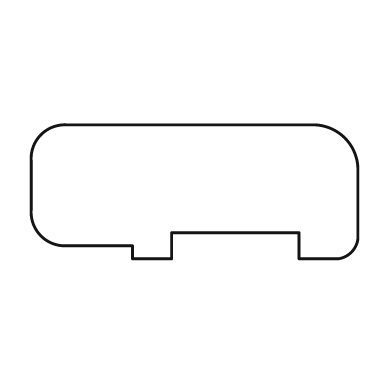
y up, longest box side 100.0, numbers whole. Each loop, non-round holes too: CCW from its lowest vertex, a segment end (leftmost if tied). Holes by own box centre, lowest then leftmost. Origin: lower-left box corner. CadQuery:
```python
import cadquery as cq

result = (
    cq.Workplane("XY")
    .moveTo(31.0, 0.0)
    .lineTo(43.0, 0.0)
    .lineTo(43.0, 8.0)
    .lineTo(82.0, 8.0)
    .lineTo(82.0, 0.0)
    .lineTo(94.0, 0.0)
    .threePointArc((98.0, 2.0), (100.0, 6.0))
    .lineTo(100.0, 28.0)
    .threePointArc((96.0, 37.0), (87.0, 41.0))
    .lineTo(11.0, 41.0)
    .threePointArc((3.0, 38.0), (0.0, 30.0))
    .lineTo(0.0, 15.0)
    .threePointArc((3.0, 7.0), (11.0, 4.0))
    .lineTo(31.0, 4.0)
    .close()
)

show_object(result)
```